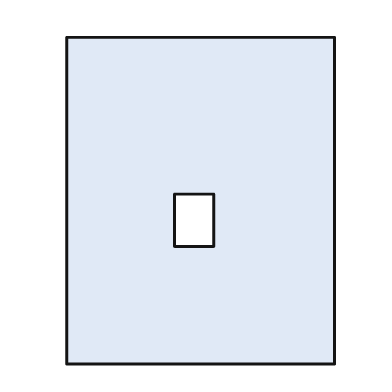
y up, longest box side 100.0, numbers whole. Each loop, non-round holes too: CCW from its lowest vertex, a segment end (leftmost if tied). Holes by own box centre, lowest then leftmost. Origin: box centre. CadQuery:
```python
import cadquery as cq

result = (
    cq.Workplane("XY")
    .moveTo(-41.0, -50.0)
    .lineTo(41.0, -50.0)
    .lineTo(41.0, 50.0)
    .lineTo(-41.0, 50.0)
    .close()
    .moveTo(-8.0, -14.0)
    .lineTo(4.0, -14.0)
    .lineTo(4.0, 2.0)
    .lineTo(-8.0, 2.0)
    .close()
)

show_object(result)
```